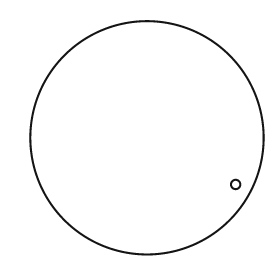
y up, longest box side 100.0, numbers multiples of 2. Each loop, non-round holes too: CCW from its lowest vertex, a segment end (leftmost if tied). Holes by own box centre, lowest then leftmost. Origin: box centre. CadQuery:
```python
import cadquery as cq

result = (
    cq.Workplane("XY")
    .moveTo(0.0, 0.0)
    .circle(50.0)
    .moveTo(38.0, -20.0)
    .circle(2.0)
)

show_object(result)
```